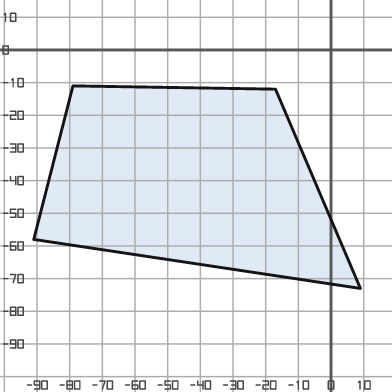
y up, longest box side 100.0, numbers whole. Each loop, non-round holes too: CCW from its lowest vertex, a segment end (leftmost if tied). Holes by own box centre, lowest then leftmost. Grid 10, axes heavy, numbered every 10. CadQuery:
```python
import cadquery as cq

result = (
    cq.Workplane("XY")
    .moveTo(9.0, -73.0)
    .lineTo(-17.0, -12.0)
    .lineTo(-79.0, -11.0)
    .lineTo(-91.0, -58.0)
    .close()
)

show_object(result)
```